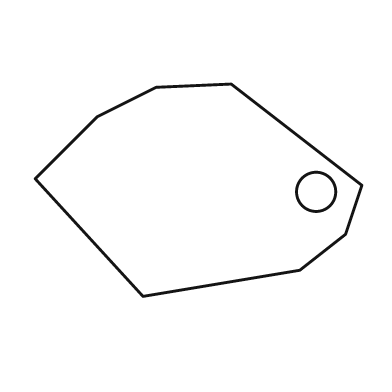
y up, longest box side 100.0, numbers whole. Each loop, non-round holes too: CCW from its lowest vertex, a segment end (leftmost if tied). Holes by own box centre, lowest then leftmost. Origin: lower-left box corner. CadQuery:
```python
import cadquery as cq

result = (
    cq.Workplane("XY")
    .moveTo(33.0, 0.0)
    .lineTo(81.0, 8.0)
    .lineTo(95.0, 19.0)
    .lineTo(100.0, 34.0)
    .lineTo(60.0, 65.0)
    .lineTo(37.0, 64.0)
    .lineTo(19.0, 55.0)
    .lineTo(0.0, 36.0)
    .close()
    .moveTo(86.0, 32.0)
    .circle(6.0)
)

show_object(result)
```